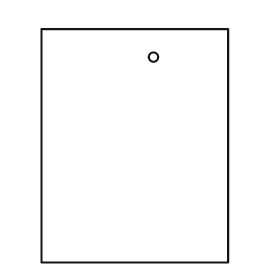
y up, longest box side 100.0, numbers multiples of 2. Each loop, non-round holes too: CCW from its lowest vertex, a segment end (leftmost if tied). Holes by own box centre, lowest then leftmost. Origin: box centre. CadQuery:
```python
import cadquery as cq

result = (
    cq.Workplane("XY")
    .moveTo(-40.0, -50.0)
    .lineTo(40.0, -50.0)
    .lineTo(40.0, 50.0)
    .lineTo(-40.0, 50.0)
    .close()
    .moveTo(8.0, 38.0)
    .circle(2.0)
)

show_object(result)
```